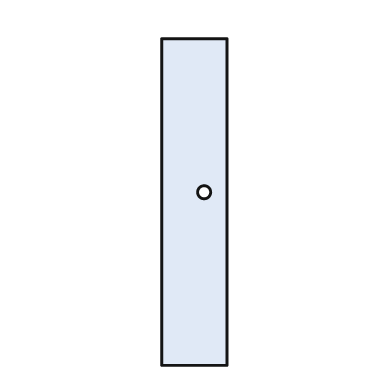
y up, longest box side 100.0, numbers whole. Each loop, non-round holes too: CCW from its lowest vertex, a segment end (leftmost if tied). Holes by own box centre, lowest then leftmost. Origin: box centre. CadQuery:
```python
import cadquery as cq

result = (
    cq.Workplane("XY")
    .moveTo(-10.0, -50.0)
    .lineTo(10.0, -50.0)
    .lineTo(10.0, 50.0)
    .lineTo(-10.0, 50.0)
    .close()
    .moveTo(3.0, 3.0)
    .circle(2.0)
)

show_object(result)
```